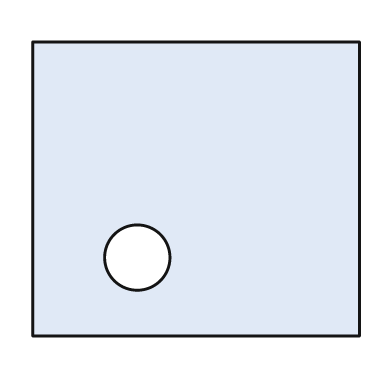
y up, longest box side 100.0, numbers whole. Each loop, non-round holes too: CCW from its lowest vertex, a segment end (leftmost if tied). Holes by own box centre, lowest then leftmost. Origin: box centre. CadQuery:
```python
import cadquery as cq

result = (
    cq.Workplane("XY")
    .moveTo(-50.0, -45.0)
    .lineTo(50.0, -45.0)
    .lineTo(50.0, 45.0)
    .lineTo(-50.0, 45.0)
    .close()
    .moveTo(-18.0, -21.0)
    .circle(10.0)
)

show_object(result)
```